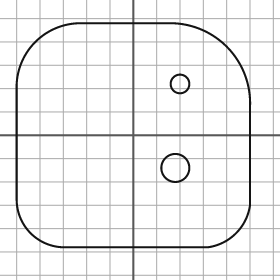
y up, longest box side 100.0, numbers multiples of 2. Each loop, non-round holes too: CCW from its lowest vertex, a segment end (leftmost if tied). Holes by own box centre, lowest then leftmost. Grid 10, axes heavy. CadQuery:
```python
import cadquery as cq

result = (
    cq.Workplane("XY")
    .moveTo(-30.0, -48.0)
    .lineTo(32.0, -48.0)
    .threePointArc((44.0, -42.0), (50.0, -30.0))
    .lineTo(50.0, 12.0)
    .threePointArc((40.0, 38.0), (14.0, 48.0))
    .lineTo(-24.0, 48.0)
    .threePointArc((-42.0, 40.0), (-50.0, 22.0))
    .lineTo(-50.0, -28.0)
    .threePointArc((-44.0, -42.0), (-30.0, -48.0))
    .close()
    .moveTo(18.0, -14.0)
    .circle(6.0)
    .moveTo(20.0, 22.0)
    .circle(4.0)
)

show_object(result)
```